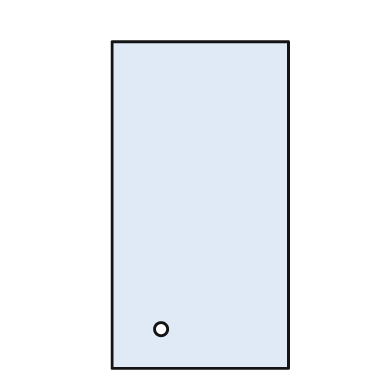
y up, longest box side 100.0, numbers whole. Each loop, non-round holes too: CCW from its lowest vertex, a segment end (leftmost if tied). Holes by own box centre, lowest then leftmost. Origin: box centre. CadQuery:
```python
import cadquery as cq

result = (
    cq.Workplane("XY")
    .moveTo(-27.0, -50.0)
    .lineTo(27.0, -50.0)
    .lineTo(27.0, 50.0)
    .lineTo(-27.0, 50.0)
    .close()
    .moveTo(-12.0, -38.0)
    .circle(2.0)
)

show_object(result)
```